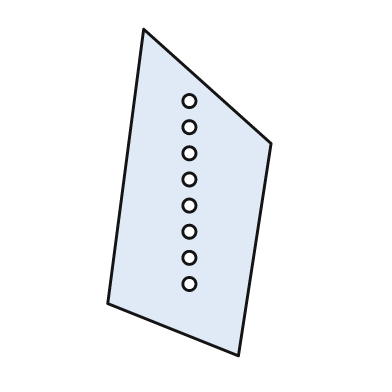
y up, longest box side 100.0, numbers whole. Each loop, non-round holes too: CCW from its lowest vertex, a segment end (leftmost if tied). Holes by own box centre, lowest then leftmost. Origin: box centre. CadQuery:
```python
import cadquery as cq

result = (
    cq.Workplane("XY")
    .moveTo(15.0, -50.0)
    .lineTo(25.0, 15.0)
    .lineTo(-14.0, 50.0)
    .lineTo(-25.0, -34.0)
    .close()
    .moveTo(0.0, -28.0)
    .circle(2.0)
    .moveTo(0.0, -20.0)
    .circle(2.0)
    .moveTo(0.0, -12.0)
    .circle(2.0)
    .moveTo(0.0, -4.0)
    .circle(2.0)
    .moveTo(0.0, 4.0)
    .circle(2.0)
    .moveTo(0.0, 12.0)
    .circle(2.0)
    .moveTo(0.0, 20.0)
    .circle(2.0)
    .moveTo(0.0, 28.0)
    .circle(2.0)
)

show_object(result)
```